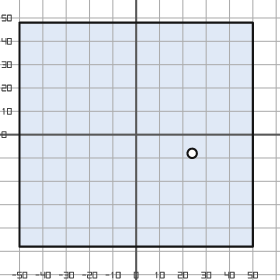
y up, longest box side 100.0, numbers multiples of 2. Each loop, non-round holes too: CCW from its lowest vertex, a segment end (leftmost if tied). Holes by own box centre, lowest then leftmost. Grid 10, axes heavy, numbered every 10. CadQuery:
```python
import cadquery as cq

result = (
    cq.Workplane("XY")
    .moveTo(-50.0, -48.0)
    .lineTo(50.0, -48.0)
    .lineTo(50.0, 48.0)
    .lineTo(-50.0, 48.0)
    .close()
    .moveTo(24.0, -8.0)
    .circle(2.0)
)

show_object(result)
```